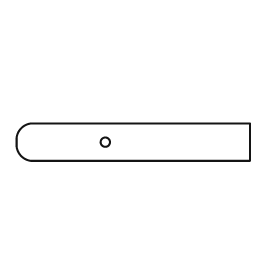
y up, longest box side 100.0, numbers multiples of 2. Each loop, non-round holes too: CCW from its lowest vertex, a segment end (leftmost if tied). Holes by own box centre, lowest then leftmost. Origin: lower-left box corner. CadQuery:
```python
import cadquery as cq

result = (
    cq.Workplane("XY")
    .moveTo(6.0, 0.0)
    .lineTo(100.0, 0.0)
    .lineTo(100.0, 16.0)
    .lineTo(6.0, 16.0)
    .threePointArc((2.0, 14.0), (0.0, 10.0))
    .lineTo(0.0, 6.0)
    .threePointArc((2.0, 2.0), (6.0, 0.0))
    .close()
    .moveTo(38.0, 8.0)
    .circle(2.0)
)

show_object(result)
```